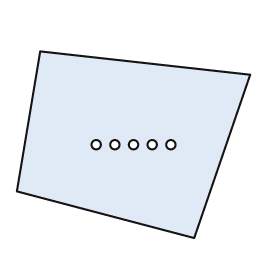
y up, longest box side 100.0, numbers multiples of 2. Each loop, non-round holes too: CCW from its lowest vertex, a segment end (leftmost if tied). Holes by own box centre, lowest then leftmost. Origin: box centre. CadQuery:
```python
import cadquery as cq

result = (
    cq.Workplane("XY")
    .moveTo(26.0, -40.0)
    .lineTo(50.0, 30.0)
    .lineTo(-40.0, 40.0)
    .lineTo(-50.0, -20.0)
    .close()
    .moveTo(-16.0, 0.0)
    .circle(2.0)
    .moveTo(-8.0, 0.0)
    .circle(2.0)
    .moveTo(0.0, 0.0)
    .circle(2.0)
    .moveTo(8.0, 0.0)
    .circle(2.0)
    .moveTo(16.0, 0.0)
    .circle(2.0)
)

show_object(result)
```